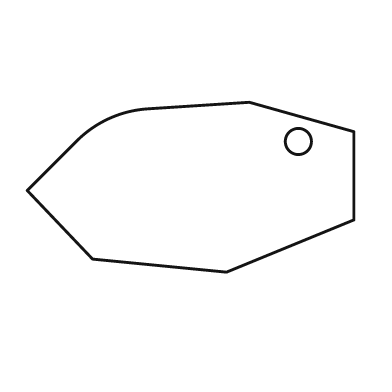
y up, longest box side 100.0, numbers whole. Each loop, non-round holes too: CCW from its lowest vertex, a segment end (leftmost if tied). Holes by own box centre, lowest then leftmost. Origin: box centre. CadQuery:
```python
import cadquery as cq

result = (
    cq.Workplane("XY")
    .moveTo(11.0, -26.0)
    .lineTo(50.0, -10.0)
    .lineTo(50.0, 17.0)
    .lineTo(18.0, 26.0)
    .lineTo(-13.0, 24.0)
    .threePointArc((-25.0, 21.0), (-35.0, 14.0))
    .lineTo(-50.0, -1.0)
    .lineTo(-30.0, -22.0)
    .close()
    .moveTo(33.0, 14.0)
    .circle(4.0)
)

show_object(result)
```